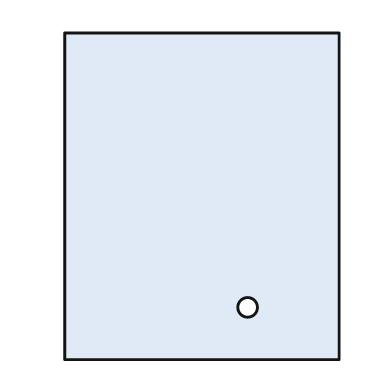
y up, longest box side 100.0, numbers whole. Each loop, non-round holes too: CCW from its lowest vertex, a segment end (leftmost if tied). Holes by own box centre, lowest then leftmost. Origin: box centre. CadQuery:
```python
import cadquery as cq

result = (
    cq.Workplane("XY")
    .moveTo(-42.0, -50.0)
    .lineTo(42.0, -50.0)
    .lineTo(42.0, 50.0)
    .lineTo(-42.0, 50.0)
    .close()
    .moveTo(14.0, -34.0)
    .circle(3.0)
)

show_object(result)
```